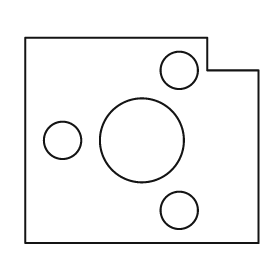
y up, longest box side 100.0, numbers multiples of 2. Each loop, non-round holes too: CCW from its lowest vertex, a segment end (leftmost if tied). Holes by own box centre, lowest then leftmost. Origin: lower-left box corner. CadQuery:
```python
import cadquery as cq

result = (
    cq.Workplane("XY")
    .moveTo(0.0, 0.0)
    .lineTo(100.0, 0.0)
    .lineTo(100.0, 74.0)
    .lineTo(78.0, 74.0)
    .lineTo(78.0, 88.0)
    .lineTo(0.0, 88.0)
    .close()
    .moveTo(66.0, 14.0)
    .circle(8.0)
    .moveTo(16.0, 44.0)
    .circle(8.0)
    .moveTo(50.0, 44.0)
    .circle(18.0)
    .moveTo(66.0, 74.0)
    .circle(8.0)
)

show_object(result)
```